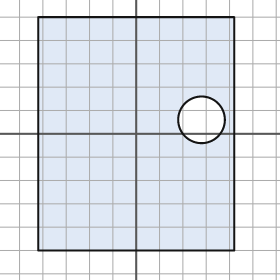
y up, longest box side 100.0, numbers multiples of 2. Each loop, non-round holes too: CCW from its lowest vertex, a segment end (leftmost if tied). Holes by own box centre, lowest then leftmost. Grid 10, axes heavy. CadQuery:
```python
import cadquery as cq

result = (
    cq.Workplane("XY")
    .moveTo(-42.0, -50.0)
    .lineTo(42.0, -50.0)
    .lineTo(42.0, 50.0)
    .lineTo(-42.0, 50.0)
    .close()
    .moveTo(28.0, 6.0)
    .circle(10.0)
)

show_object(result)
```